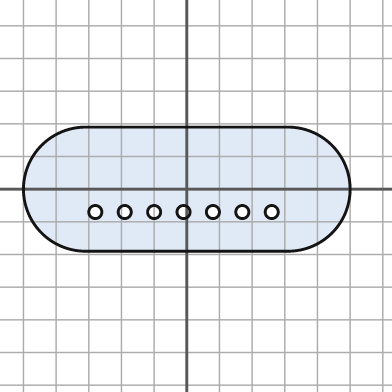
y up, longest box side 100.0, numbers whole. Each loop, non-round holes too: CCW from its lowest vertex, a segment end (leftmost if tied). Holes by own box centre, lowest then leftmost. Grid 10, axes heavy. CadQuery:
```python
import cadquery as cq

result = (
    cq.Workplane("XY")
    .moveTo(-31.0, -19.0)
    .lineTo(31.0, -19.0)
    .threePointArc((50.0, 0.0), (31.0, 19.0))
    .lineTo(-31.0, 19.0)
    .threePointArc((-50.0, 0.0), (-31.0, -19.0))
    .close()
    .moveTo(-28.0, -7.0)
    .circle(2.0)
    .moveTo(-19.0, -7.0)
    .circle(2.0)
    .moveTo(-10.0, -7.0)
    .circle(2.0)
    .moveTo(-1.0, -7.0)
    .circle(2.0)
    .moveTo(8.0, -7.0)
    .circle(2.0)
    .moveTo(17.0, -7.0)
    .circle(2.0)
    .moveTo(26.0, -7.0)
    .circle(2.0)
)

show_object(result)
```